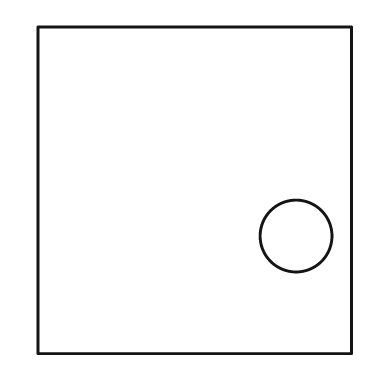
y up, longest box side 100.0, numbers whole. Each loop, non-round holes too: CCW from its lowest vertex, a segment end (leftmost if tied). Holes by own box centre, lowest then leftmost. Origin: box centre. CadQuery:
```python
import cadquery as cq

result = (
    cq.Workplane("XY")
    .moveTo(-48.0, -50.0)
    .lineTo(48.0, -50.0)
    .lineTo(48.0, 50.0)
    .lineTo(-48.0, 50.0)
    .close()
    .moveTo(31.0, -14.0)
    .circle(11.0)
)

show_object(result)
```